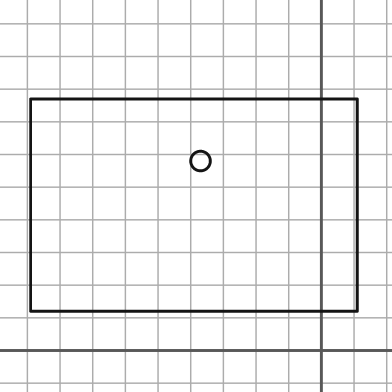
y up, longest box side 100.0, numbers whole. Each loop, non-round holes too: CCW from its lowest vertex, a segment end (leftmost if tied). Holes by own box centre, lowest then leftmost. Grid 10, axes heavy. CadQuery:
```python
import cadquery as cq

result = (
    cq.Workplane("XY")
    .moveTo(-89.0, 12.0)
    .lineTo(11.0, 12.0)
    .lineTo(11.0, 77.0)
    .lineTo(-89.0, 77.0)
    .close()
    .moveTo(-37.0, 58.0)
    .circle(3.0)
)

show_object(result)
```